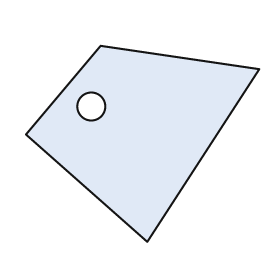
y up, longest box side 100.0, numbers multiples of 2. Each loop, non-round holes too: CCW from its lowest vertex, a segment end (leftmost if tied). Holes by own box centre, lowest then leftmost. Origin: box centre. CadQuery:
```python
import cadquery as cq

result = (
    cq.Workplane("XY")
    .moveTo(2.0, -42.0)
    .lineTo(50.0, 32.0)
    .lineTo(-18.0, 42.0)
    .lineTo(-50.0, 4.0)
    .close()
    .moveTo(-22.0, 16.0)
    .circle(6.0)
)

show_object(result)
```